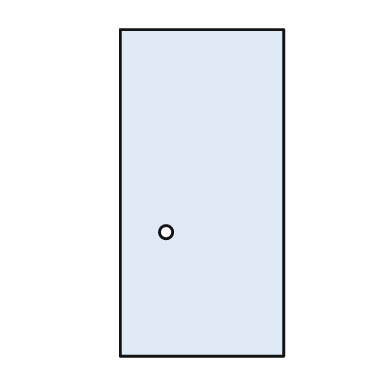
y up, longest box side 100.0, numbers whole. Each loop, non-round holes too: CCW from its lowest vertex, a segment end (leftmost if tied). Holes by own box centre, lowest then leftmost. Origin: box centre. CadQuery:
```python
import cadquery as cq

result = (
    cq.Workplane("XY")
    .moveTo(-25.0, -50.0)
    .lineTo(25.0, -50.0)
    .lineTo(25.0, 50.0)
    .lineTo(-25.0, 50.0)
    .close()
    .moveTo(-11.0, -12.0)
    .circle(2.0)
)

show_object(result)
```